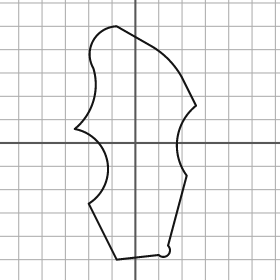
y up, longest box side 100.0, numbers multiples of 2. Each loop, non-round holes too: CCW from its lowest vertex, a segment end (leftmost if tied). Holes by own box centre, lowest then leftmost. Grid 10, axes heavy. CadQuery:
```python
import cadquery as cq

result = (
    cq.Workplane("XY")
    .moveTo(-8.0, -50.0)
    .lineTo(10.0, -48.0)
    .threePointArc((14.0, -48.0), (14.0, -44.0))
    .lineTo(22.0, -14.0)
    .threePointArc((18.0, 2.0), (26.0, 16.0))
    .lineTo(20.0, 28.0)
    .threePointArc((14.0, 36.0), (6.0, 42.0))
    .lineTo(-8.0, 50.0)
    .threePointArc((-18.0, 44.0), (-18.0, 32.0))
    .threePointArc((-18.0, 18.0), (-26.0, 6.0))
    .threePointArc((-12.0, -8.0), (-20.0, -26.0))
    .close()
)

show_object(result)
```